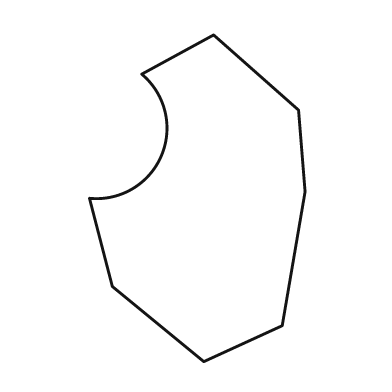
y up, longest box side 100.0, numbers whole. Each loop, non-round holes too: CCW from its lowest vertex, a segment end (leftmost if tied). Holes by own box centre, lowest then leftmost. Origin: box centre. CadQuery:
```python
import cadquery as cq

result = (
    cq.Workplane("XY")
    .moveTo(2.0, -50.0)
    .lineTo(26.0, -39.0)
    .lineTo(33.0, 2.0)
    .lineTo(31.0, 27.0)
    .lineTo(5.0, 50.0)
    .lineTo(-17.0, 38.0)
    .threePointArc((-11.0, 13.0), (-33.0, 0.0))
    .lineTo(-26.0, -27.0)
    .close()
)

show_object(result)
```